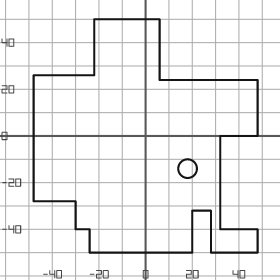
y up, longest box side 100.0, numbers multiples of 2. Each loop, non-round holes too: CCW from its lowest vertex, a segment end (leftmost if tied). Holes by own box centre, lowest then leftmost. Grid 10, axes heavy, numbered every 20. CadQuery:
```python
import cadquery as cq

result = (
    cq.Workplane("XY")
    .moveTo(-24.0, -50.0)
    .lineTo(20.0, -50.0)
    .lineTo(20.0, -32.0)
    .lineTo(28.0, -32.0)
    .lineTo(28.0, -50.0)
    .lineTo(48.0, -50.0)
    .lineTo(48.0, -40.0)
    .lineTo(32.0, -40.0)
    .lineTo(32.0, 0.0)
    .lineTo(48.0, 0.0)
    .lineTo(48.0, 24.0)
    .lineTo(6.0, 24.0)
    .lineTo(6.0, 50.0)
    .lineTo(-22.0, 50.0)
    .lineTo(-22.0, 26.0)
    .lineTo(-48.0, 26.0)
    .lineTo(-48.0, -28.0)
    .lineTo(-30.0, -28.0)
    .lineTo(-30.0, -40.0)
    .lineTo(-24.0, -40.0)
    .close()
    .moveTo(18.0, -14.0)
    .circle(4.0)
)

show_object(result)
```